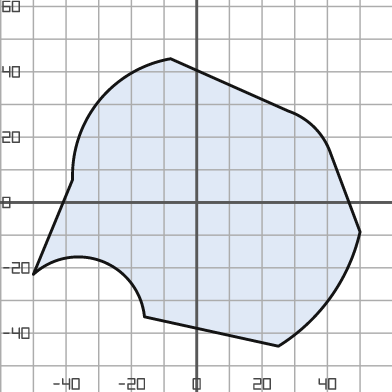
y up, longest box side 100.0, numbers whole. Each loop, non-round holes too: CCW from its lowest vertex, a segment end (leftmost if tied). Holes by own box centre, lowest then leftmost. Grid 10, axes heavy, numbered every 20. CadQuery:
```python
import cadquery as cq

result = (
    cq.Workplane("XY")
    .moveTo(25.0, -44.0)
    .threePointArc((41.0, -29.0), (50.0, -9.0))
    .lineTo(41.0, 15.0)
    .threePointArc((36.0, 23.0), (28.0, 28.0))
    .lineTo(-8.0, 44.0)
    .threePointArc((-30.0, 31.0), (-38.0, 7.0))
    .lineTo(-50.0, -22.0)
    .threePointArc((-29.0, -18.0), (-16.0, -35.0))
    .close()
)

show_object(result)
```